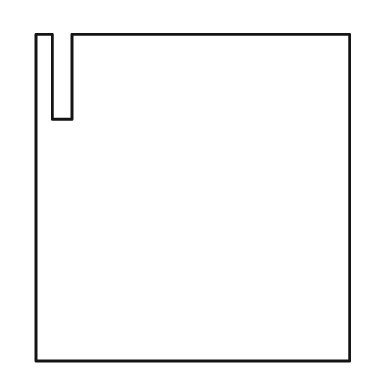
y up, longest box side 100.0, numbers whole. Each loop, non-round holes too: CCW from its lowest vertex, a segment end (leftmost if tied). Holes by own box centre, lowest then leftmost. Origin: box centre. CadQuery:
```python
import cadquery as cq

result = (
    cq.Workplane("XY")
    .moveTo(-48.0, -50.0)
    .lineTo(48.0, -50.0)
    .lineTo(48.0, 50.0)
    .lineTo(-37.0, 50.0)
    .lineTo(-37.0, 24.0)
    .lineTo(-43.0, 24.0)
    .lineTo(-43.0, 50.0)
    .lineTo(-48.0, 50.0)
    .close()
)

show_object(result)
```